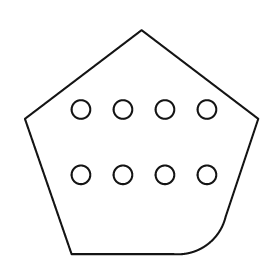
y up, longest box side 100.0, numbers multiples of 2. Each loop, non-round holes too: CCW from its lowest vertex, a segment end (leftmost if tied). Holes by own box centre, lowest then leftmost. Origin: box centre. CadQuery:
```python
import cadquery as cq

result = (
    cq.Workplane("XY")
    .moveTo(-30.0, -48.0)
    .lineTo(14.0, -48.0)
    .threePointArc((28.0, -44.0), (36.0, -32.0))
    .lineTo(50.0, 10.0)
    .lineTo(0.0, 48.0)
    .lineTo(-50.0, 10.0)
    .close()
    .moveTo(-26.0, -14.0)
    .circle(4.0)
    .moveTo(-8.0, -14.0)
    .circle(4.0)
    .moveTo(10.0, -14.0)
    .circle(4.0)
    .moveTo(28.0, -14.0)
    .circle(4.0)
    .moveTo(-26.0, 14.0)
    .circle(4.0)
    .moveTo(-8.0, 14.0)
    .circle(4.0)
    .moveTo(10.0, 14.0)
    .circle(4.0)
    .moveTo(28.0, 14.0)
    .circle(4.0)
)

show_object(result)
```